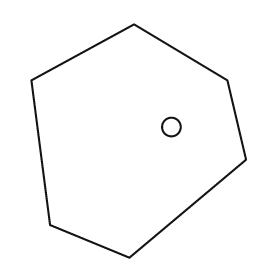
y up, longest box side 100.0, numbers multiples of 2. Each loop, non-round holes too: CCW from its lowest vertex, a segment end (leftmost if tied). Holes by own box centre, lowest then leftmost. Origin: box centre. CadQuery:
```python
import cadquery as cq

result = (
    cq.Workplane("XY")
    .moveTo(-4.0, -50.0)
    .lineTo(46.0, -8.0)
    .lineTo(38.0, 26.0)
    .lineTo(-2.0, 50.0)
    .lineTo(-46.0, 26.0)
    .lineTo(-38.0, -36.0)
    .close()
    .moveTo(14.0, 6.0)
    .circle(4.0)
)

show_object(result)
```